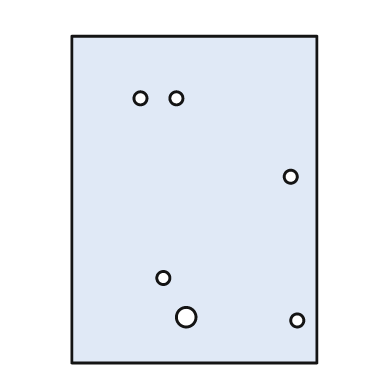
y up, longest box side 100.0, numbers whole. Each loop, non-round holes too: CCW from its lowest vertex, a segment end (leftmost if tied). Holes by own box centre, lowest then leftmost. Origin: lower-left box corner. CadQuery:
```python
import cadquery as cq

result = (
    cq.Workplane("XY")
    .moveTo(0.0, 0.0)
    .lineTo(75.0, 0.0)
    .lineTo(75.0, 100.0)
    .lineTo(0.0, 100.0)
    .close()
    .moveTo(69.0, 13.0)
    .circle(2.0)
    .moveTo(35.0, 14.0)
    .circle(3.0)
    .moveTo(28.0, 26.0)
    .circle(2.0)
    .moveTo(67.0, 57.0)
    .circle(2.0)
    .moveTo(21.0, 81.0)
    .circle(2.0)
    .moveTo(32.0, 81.0)
    .circle(2.0)
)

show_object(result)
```